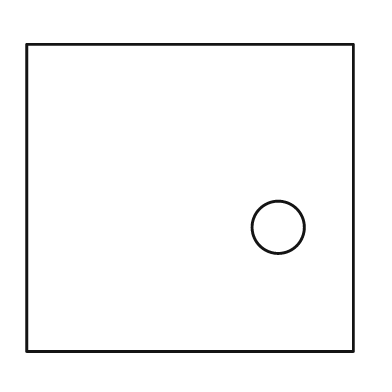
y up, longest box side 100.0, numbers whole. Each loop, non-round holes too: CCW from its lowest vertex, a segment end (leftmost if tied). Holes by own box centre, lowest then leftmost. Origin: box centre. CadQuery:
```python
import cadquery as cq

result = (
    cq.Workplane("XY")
    .moveTo(-50.0, -47.0)
    .lineTo(50.0, -47.0)
    .lineTo(50.0, 47.0)
    .lineTo(-50.0, 47.0)
    .close()
    .moveTo(27.0, -9.0)
    .circle(8.0)
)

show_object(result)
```